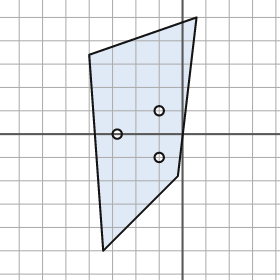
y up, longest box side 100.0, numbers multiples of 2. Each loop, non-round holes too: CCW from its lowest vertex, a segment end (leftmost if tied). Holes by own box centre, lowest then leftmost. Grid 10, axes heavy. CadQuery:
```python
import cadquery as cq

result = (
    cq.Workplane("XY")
    .moveTo(-34.0, -50.0)
    .lineTo(-2.0, -18.0)
    .lineTo(6.0, 50.0)
    .lineTo(-40.0, 34.0)
    .close()
    .moveTo(-10.0, -10.0)
    .circle(2.0)
    .moveTo(-28.0, 0.0)
    .circle(2.0)
    .moveTo(-10.0, 10.0)
    .circle(2.0)
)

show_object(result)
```